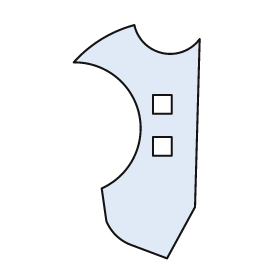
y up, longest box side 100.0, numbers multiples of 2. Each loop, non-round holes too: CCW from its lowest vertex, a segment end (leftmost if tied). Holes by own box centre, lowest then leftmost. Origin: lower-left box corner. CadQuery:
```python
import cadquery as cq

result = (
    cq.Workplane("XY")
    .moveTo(40.0, 0.0)
    .lineTo(52.0, 22.0)
    .lineTo(54.0, 94.0)
    .threePointArc((38.0, 88.0), (26.0, 100.0))
    .threePointArc((12.0, 94.0), (0.0, 84.0))
    .threePointArc((28.0, 62.0), (12.0, 30.0))
    .lineTo(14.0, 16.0)
    .threePointArc((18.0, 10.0), (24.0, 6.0))
    .close()
    .moveTo(34.0, 44.0)
    .lineTo(42.0, 44.0)
    .lineTo(42.0, 52.0)
    .lineTo(34.0, 52.0)
    .close()
    .moveTo(34.0, 62.0)
    .lineTo(42.0, 62.0)
    .lineTo(42.0, 70.0)
    .lineTo(34.0, 70.0)
    .close()
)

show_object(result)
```